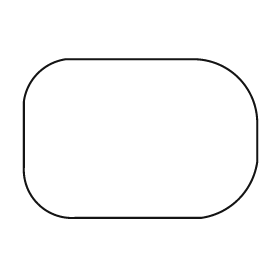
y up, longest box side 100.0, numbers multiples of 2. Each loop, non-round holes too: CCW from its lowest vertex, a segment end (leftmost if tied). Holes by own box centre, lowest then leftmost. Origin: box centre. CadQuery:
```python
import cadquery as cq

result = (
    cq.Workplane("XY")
    .moveTo(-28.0, -34.0)
    .lineTo(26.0, -34.0)
    .threePointArc((42.0, -26.0), (50.0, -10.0))
    .lineTo(50.0, 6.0)
    .threePointArc((42.0, 26.0), (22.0, 34.0))
    .lineTo(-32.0, 34.0)
    .threePointArc((-44.0, 28.0), (-50.0, 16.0))
    .lineTo(-50.0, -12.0)
    .threePointArc((-44.0, -28.0), (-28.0, -34.0))
    .close()
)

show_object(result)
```